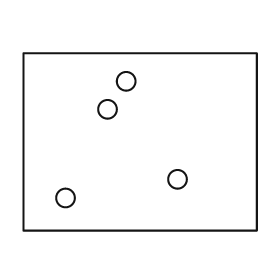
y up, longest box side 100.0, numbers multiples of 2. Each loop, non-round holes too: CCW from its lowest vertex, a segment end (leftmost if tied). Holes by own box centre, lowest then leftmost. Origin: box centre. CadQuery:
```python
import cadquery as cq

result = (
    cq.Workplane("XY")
    .moveTo(-50.0, -38.0)
    .lineTo(50.0, -38.0)
    .lineTo(50.0, 38.0)
    .lineTo(-50.0, 38.0)
    .close()
    .moveTo(-32.0, -24.0)
    .circle(4.0)
    .moveTo(16.0, -16.0)
    .circle(4.0)
    .moveTo(-14.0, 14.0)
    .circle(4.0)
    .moveTo(-6.0, 26.0)
    .circle(4.0)
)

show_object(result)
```